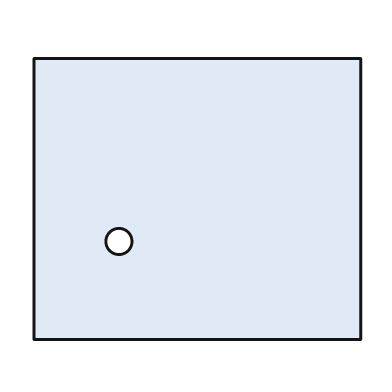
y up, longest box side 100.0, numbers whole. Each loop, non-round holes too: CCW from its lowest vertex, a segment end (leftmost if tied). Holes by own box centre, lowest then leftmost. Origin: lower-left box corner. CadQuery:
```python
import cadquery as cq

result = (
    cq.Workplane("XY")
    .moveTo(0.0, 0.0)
    .lineTo(100.0, 0.0)
    .lineTo(100.0, 86.0)
    .lineTo(0.0, 86.0)
    .close()
    .moveTo(26.0, 30.0)
    .circle(4.0)
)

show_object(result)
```